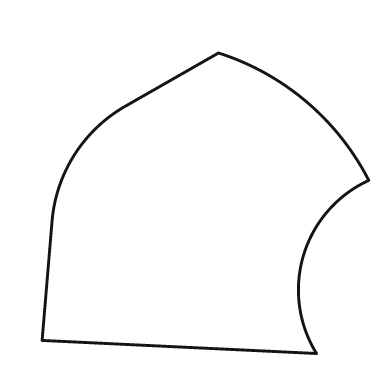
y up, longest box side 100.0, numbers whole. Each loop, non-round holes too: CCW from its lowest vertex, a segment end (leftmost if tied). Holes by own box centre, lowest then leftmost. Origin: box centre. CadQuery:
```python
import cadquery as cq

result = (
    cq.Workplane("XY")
    .moveTo(34.0, -46.0)
    .threePointArc((30.0, -16.0), (50.0, 7.0))
    .threePointArc((31.0, 31.0), (4.0, 46.0))
    .lineTo(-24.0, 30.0)
    .threePointArc((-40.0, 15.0), (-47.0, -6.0))
    .lineTo(-50.0, -42.0)
    .close()
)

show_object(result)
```